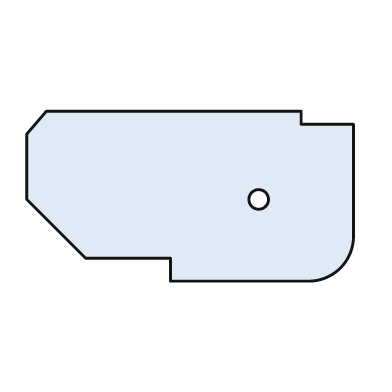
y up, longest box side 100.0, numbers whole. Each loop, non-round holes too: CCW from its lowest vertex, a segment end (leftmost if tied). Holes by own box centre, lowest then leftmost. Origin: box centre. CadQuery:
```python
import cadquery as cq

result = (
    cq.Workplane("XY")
    .moveTo(-6.0, -26.0)
    .lineTo(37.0, -26.0)
    .threePointArc((46.0, -22.0), (50.0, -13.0))
    .lineTo(50.0, 22.0)
    .lineTo(34.0, 22.0)
    .lineTo(34.0, 26.0)
    .lineTo(-44.0, 26.0)
    .lineTo(-50.0, 19.0)
    .lineTo(-50.0, -1.0)
    .lineTo(-32.0, -19.0)
    .lineTo(-6.0, -19.0)
    .close()
    .moveTo(21.0, -1.0)
    .circle(3.0)
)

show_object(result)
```